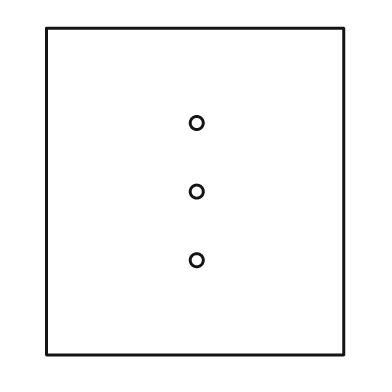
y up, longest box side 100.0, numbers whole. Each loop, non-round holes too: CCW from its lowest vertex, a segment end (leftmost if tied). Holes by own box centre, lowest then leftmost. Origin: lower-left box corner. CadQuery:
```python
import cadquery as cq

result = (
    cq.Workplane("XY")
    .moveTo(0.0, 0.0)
    .lineTo(91.0, 0.0)
    .lineTo(91.0, 100.0)
    .lineTo(0.0, 100.0)
    .close()
    .moveTo(46.0, 29.0)
    .circle(2.0)
    .moveTo(46.0, 50.0)
    .circle(2.0)
    .moveTo(46.0, 71.0)
    .circle(2.0)
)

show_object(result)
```